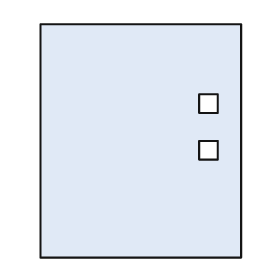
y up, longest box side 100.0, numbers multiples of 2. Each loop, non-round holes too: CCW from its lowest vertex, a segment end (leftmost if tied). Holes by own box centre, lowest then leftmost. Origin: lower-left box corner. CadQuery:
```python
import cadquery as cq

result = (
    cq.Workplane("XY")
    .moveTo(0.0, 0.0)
    .lineTo(86.0, 0.0)
    .lineTo(86.0, 100.0)
    .lineTo(0.0, 100.0)
    .close()
    .moveTo(68.0, 42.0)
    .lineTo(76.0, 42.0)
    .lineTo(76.0, 50.0)
    .lineTo(68.0, 50.0)
    .close()
    .moveTo(68.0, 62.0)
    .lineTo(76.0, 62.0)
    .lineTo(76.0, 70.0)
    .lineTo(68.0, 70.0)
    .close()
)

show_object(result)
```